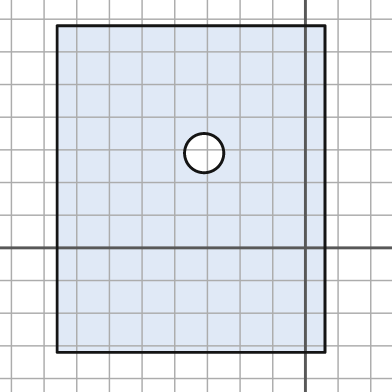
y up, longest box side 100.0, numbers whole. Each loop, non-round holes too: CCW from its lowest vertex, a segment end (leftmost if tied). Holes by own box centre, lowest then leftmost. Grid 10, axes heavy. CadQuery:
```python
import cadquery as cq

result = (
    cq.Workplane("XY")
    .moveTo(-76.0, -32.0)
    .lineTo(6.0, -32.0)
    .lineTo(6.0, 68.0)
    .lineTo(-76.0, 68.0)
    .close()
    .moveTo(-31.0, 29.0)
    .circle(6.0)
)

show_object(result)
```